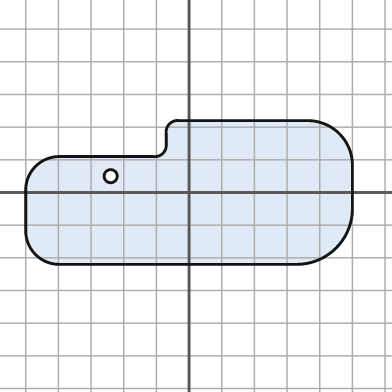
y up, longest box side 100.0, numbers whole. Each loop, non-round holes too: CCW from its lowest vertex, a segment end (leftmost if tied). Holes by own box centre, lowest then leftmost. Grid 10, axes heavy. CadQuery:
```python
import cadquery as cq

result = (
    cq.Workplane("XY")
    .moveTo(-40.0, -22.0)
    .lineTo(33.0, -22.0)
    .threePointArc((45.0, -17.0), (50.0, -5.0))
    .lineTo(50.0, 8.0)
    .threePointArc((46.0, 18.0), (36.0, 22.0))
    .lineTo(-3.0, 22.0)
    .threePointArc((-6.0, 21.0), (-7.0, 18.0))
    .lineTo(-7.0, 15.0)
    .threePointArc((-8.0, 12.0), (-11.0, 11.0))
    .lineTo(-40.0, 11.0)
    .threePointArc((-47.0, 8.0), (-50.0, 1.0))
    .lineTo(-50.0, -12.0)
    .threePointArc((-47.0, -19.0), (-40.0, -22.0))
    .close()
    .moveTo(-24.0, 5.0)
    .circle(2.0)
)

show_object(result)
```